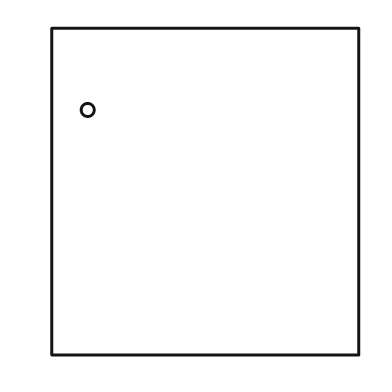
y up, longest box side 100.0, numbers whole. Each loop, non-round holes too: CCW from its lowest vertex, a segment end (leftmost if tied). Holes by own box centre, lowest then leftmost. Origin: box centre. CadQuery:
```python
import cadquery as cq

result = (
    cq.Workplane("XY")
    .moveTo(-47.0, -50.0)
    .lineTo(47.0, -50.0)
    .lineTo(47.0, 50.0)
    .lineTo(-47.0, 50.0)
    .close()
    .moveTo(-36.0, 25.0)
    .circle(2.0)
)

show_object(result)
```